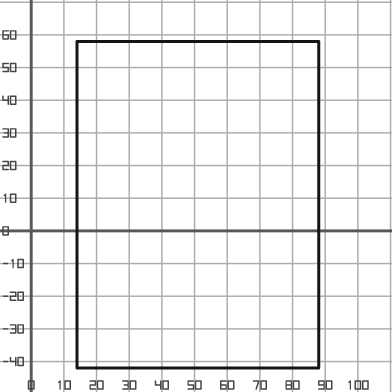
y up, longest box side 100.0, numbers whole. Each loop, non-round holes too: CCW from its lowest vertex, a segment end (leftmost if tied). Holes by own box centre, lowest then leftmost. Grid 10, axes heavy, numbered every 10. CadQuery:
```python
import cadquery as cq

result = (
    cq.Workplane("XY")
    .moveTo(14.0, -42.0)
    .lineTo(88.0, -42.0)
    .lineTo(88.0, 58.0)
    .lineTo(14.0, 58.0)
    .close()
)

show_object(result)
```